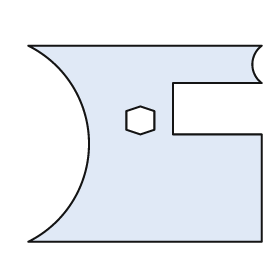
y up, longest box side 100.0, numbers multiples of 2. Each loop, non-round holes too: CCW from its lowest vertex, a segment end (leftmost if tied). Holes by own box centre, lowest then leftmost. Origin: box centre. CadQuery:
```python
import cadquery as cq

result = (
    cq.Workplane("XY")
    .moveTo(-50.0, -42.0)
    .lineTo(50.0, -42.0)
    .lineTo(50.0, 4.0)
    .lineTo(12.0, 4.0)
    .lineTo(12.0, 26.0)
    .lineTo(50.0, 26.0)
    .threePointArc((46.0, 34.0), (50.0, 42.0))
    .lineTo(-50.0, 42.0)
    .threePointArc((-24.0, 0.0), (-50.0, -42.0))
    .close()
    .moveTo(-2.0, 4.0)
    .lineTo(4.0, 6.0)
    .lineTo(4.0, 14.0)
    .lineTo(-2.0, 16.0)
    .lineTo(-8.0, 14.0)
    .lineTo(-8.0, 6.0)
    .close()
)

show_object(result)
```